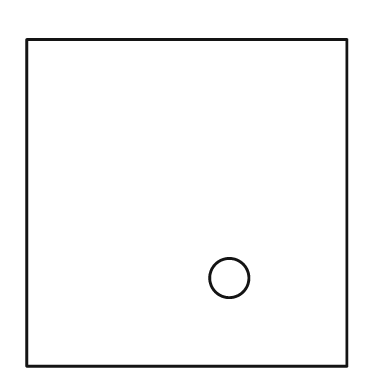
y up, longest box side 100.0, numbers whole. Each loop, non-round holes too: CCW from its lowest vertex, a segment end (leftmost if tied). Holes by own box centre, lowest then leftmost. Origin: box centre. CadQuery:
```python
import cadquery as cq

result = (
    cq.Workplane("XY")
    .moveTo(-49.0, -50.0)
    .lineTo(49.0, -50.0)
    .lineTo(49.0, 50.0)
    .lineTo(-49.0, 50.0)
    .close()
    .moveTo(13.0, -23.0)
    .circle(6.0)
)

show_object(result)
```